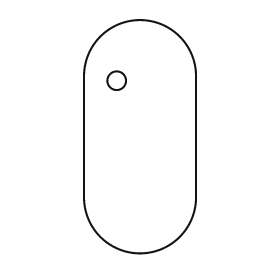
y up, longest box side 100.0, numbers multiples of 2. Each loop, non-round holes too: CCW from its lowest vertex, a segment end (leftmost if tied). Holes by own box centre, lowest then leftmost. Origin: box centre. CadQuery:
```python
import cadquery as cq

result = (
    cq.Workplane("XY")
    .moveTo(-24.0, -26.0)
    .threePointArc((0.0, -50.0), (24.0, -26.0))
    .lineTo(24.0, 26.0)
    .threePointArc((0.0, 50.0), (-24.0, 26.0))
    .close()
    .moveTo(-10.0, 24.0)
    .circle(4.0)
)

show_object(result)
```